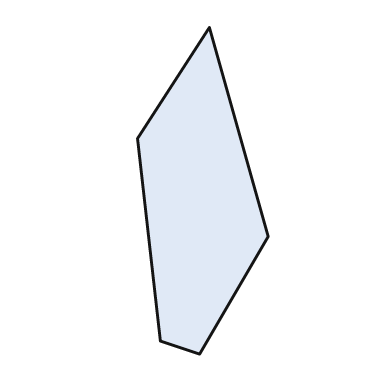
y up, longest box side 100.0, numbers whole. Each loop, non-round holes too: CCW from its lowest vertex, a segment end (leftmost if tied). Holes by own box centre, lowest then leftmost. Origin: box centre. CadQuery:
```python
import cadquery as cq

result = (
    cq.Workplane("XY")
    .moveTo(-1.0, -50.0)
    .lineTo(20.0, -14.0)
    .lineTo(2.0, 50.0)
    .lineTo(-20.0, 16.0)
    .lineTo(-13.0, -46.0)
    .close()
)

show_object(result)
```